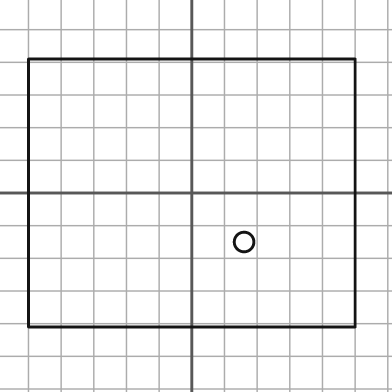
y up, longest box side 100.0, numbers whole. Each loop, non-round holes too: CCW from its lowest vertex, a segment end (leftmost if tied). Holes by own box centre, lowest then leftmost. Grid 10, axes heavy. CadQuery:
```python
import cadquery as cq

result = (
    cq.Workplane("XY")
    .moveTo(-50.0, -41.0)
    .lineTo(50.0, -41.0)
    .lineTo(50.0, 41.0)
    .lineTo(-50.0, 41.0)
    .close()
    .moveTo(16.0, -15.0)
    .circle(3.0)
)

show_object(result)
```